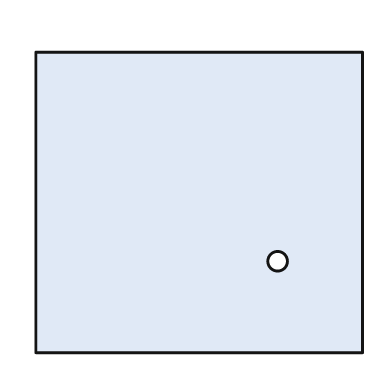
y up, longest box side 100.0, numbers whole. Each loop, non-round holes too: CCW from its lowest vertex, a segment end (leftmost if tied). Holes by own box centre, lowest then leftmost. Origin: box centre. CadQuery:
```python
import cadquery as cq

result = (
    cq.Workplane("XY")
    .moveTo(-50.0, -46.0)
    .lineTo(50.0, -46.0)
    .lineTo(50.0, 46.0)
    .lineTo(-50.0, 46.0)
    .close()
    .moveTo(24.0, -18.0)
    .circle(3.0)
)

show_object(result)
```